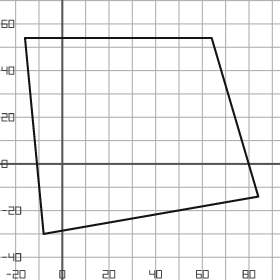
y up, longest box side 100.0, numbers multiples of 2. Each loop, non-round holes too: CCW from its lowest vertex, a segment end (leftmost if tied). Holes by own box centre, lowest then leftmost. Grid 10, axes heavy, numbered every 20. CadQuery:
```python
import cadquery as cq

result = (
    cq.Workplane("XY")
    .moveTo(-8.0, -30.0)
    .lineTo(84.0, -14.0)
    .lineTo(64.0, 54.0)
    .lineTo(-16.0, 54.0)
    .close()
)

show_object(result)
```